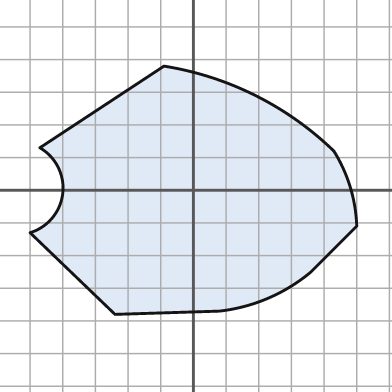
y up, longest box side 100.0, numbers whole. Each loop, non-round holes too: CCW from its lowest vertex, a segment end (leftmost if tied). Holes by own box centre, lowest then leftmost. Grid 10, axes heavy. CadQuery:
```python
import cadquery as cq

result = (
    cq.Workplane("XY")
    .moveTo(-24.0, -38.0)
    .lineTo(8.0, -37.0)
    .threePointArc((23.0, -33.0), (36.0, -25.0))
    .lineTo(50.0, -11.0)
    .threePointArc((48.0, 1.0), (43.0, 12.0))
    .threePointArc((19.0, 29.0), (-9.0, 38.0))
    .lineTo(-47.0, 13.0)
    .threePointArc((-40.0, -1.0), (-50.0, -13.0))
    .close()
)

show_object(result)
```